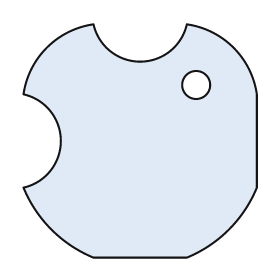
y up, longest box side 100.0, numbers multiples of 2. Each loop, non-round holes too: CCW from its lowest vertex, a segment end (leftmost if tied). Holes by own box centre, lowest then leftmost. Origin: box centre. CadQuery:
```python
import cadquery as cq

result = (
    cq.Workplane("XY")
    .moveTo(-20.0, -50.0)
    .lineTo(20.0, -50.0)
    .threePointArc((38.0, -38.0), (50.0, -20.0))
    .lineTo(50.0, 20.0)
    .threePointArc((40.0, 40.0), (20.0, 50.0))
    .threePointArc((0.0, 34.0), (-20.0, 50.0))
    .threePointArc((-40.0, 40.0), (-50.0, 20.0))
    .threePointArc((-34.0, 0.0), (-50.0, -20.0))
    .threePointArc((-38.0, -38.0), (-20.0, -50.0))
    .close()
    .moveTo(24.0, 24.0)
    .circle(6.0)
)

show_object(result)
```